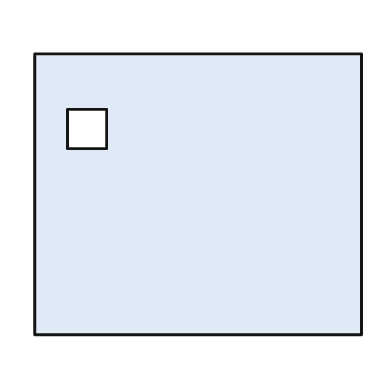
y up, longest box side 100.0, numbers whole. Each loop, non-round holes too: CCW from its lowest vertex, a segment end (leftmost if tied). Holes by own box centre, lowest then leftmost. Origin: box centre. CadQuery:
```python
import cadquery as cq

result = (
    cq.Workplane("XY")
    .moveTo(-50.0, -43.0)
    .lineTo(50.0, -43.0)
    .lineTo(50.0, 43.0)
    .lineTo(-50.0, 43.0)
    .close()
    .moveTo(-40.0, 14.0)
    .lineTo(-28.0, 14.0)
    .lineTo(-28.0, 26.0)
    .lineTo(-40.0, 26.0)
    .close()
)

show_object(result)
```